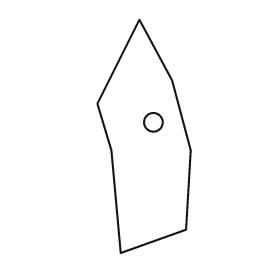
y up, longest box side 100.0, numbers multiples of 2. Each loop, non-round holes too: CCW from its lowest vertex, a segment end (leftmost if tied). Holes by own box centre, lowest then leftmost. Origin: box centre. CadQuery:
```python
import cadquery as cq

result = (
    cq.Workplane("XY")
    .moveTo(-10.0, -50.0)
    .lineTo(18.0, -40.0)
    .lineTo(20.0, -6.0)
    .lineTo(12.0, 24.0)
    .lineTo(-2.0, 50.0)
    .lineTo(-20.0, 14.0)
    .lineTo(-14.0, -6.0)
    .close()
    .moveTo(4.0, 6.0)
    .circle(4.0)
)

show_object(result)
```